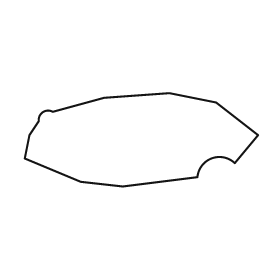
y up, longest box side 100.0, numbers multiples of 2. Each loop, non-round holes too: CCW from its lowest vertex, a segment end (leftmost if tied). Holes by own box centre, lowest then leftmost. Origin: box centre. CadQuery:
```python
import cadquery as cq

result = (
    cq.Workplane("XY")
    .moveTo(-8.0, -20.0)
    .lineTo(24.0, -16.0)
    .threePointArc((30.0, -8.0), (40.0, -10.0))
    .lineTo(50.0, 2.0)
    .lineTo(32.0, 16.0)
    .lineTo(12.0, 20.0)
    .lineTo(-16.0, 18.0)
    .lineTo(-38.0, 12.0)
    .threePointArc((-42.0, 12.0), (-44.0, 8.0))
    .lineTo(-48.0, 2.0)
    .lineTo(-50.0, -8.0)
    .lineTo(-26.0, -18.0)
    .close()
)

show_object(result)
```